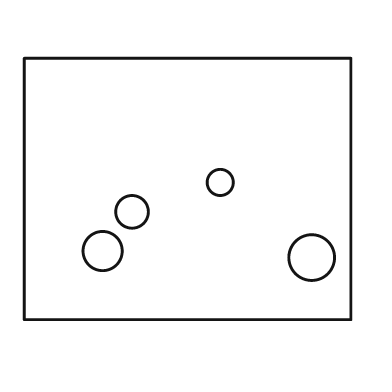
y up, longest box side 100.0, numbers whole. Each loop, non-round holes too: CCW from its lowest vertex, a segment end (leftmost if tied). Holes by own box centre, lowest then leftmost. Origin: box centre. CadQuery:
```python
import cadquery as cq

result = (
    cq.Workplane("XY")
    .moveTo(-50.0, -40.0)
    .lineTo(50.0, -40.0)
    .lineTo(50.0, 40.0)
    .lineTo(-50.0, 40.0)
    .close()
    .moveTo(38.0, -21.0)
    .circle(7.0)
    .moveTo(-26.0, -19.0)
    .circle(6.0)
    .moveTo(-17.0, -7.0)
    .circle(5.0)
    .moveTo(10.0, 2.0)
    .circle(4.0)
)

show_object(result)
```